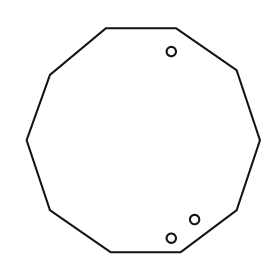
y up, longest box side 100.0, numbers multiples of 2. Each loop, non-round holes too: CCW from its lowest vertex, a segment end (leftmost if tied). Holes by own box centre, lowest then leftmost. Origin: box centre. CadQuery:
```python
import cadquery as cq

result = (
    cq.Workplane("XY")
    .moveTo(-14.0, -48.0)
    .lineTo(16.0, -48.0)
    .lineTo(40.0, -30.0)
    .lineTo(50.0, 0.0)
    .lineTo(40.0, 30.0)
    .lineTo(14.0, 48.0)
    .lineTo(-16.0, 48.0)
    .lineTo(-40.0, 28.0)
    .lineTo(-50.0, 0.0)
    .lineTo(-40.0, -30.0)
    .close()
    .moveTo(12.0, -42.0)
    .circle(2.0)
    .moveTo(22.0, -34.0)
    .circle(2.0)
    .moveTo(12.0, 38.0)
    .circle(2.0)
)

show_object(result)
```